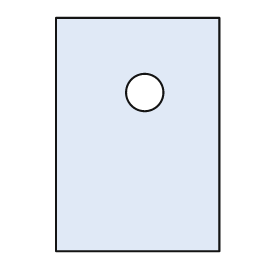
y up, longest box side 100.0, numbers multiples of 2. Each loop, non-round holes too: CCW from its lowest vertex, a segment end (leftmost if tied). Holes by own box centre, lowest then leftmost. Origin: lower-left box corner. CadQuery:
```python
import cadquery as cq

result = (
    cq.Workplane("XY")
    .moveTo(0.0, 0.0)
    .lineTo(70.0, 0.0)
    .lineTo(70.0, 100.0)
    .lineTo(0.0, 100.0)
    .close()
    .moveTo(38.0, 68.0)
    .circle(8.0)
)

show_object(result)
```